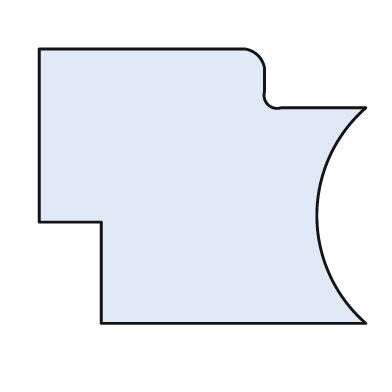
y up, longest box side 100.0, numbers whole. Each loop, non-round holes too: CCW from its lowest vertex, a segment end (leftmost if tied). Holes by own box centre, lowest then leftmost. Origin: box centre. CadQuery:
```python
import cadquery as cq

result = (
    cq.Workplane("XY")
    .moveTo(-31.0, -42.0)
    .lineTo(50.0, -42.0)
    .threePointArc((35.0, -9.0), (50.0, 24.0))
    .lineTo(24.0, 24.0)
    .threePointArc((20.0, 25.0), (19.0, 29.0))
    .lineTo(19.0, 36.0)
    .threePointArc((17.0, 40.0), (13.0, 42.0))
    .lineTo(-50.0, 42.0)
    .lineTo(-50.0, -11.0)
    .lineTo(-31.0, -11.0)
    .close()
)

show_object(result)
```